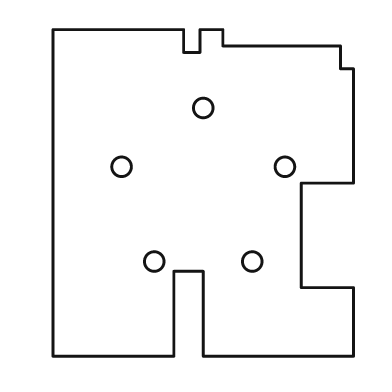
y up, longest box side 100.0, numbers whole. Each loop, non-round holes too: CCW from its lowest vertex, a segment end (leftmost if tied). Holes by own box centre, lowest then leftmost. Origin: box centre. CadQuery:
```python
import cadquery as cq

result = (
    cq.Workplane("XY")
    .moveTo(-46.0, -50.0)
    .lineTo(-9.0, -50.0)
    .lineTo(-9.0, -24.0)
    .lineTo(0.0, -24.0)
    .lineTo(0.0, -50.0)
    .lineTo(46.0, -50.0)
    .lineTo(46.0, -29.0)
    .lineTo(30.0, -29.0)
    .lineTo(30.0, 3.0)
    .lineTo(46.0, 3.0)
    .lineTo(46.0, 38.0)
    .lineTo(42.0, 38.0)
    .lineTo(42.0, 45.0)
    .lineTo(6.0, 45.0)
    .lineTo(6.0, 50.0)
    .lineTo(-1.0, 50.0)
    .lineTo(-1.0, 43.0)
    .lineTo(-6.0, 43.0)
    .lineTo(-6.0, 50.0)
    .lineTo(-46.0, 50.0)
    .close()
    .moveTo(-15.0, -21.0)
    .circle(3.0)
    .moveTo(15.0, -21.0)
    .circle(3.0)
    .moveTo(-25.0, 8.0)
    .circle(3.0)
    .moveTo(25.0, 8.0)
    .circle(3.0)
    .moveTo(0.0, 26.0)
    .circle(3.0)
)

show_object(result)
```